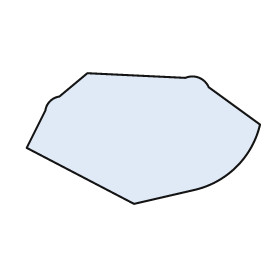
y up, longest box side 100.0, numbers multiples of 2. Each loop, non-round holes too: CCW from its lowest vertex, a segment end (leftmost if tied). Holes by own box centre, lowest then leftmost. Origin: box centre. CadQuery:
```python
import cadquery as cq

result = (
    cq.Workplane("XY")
    .moveTo(-4.0, -28.0)
    .lineTo(22.0, -22.0)
    .threePointArc((40.0, -12.0), (50.0, 6.0))
    .lineTo(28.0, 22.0)
    .threePointArc((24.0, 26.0), (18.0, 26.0))
    .lineTo(-24.0, 28.0)
    .lineTo(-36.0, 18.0)
    .threePointArc((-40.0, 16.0), (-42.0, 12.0))
    .lineTo(-50.0, -4.0)
    .close()
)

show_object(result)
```